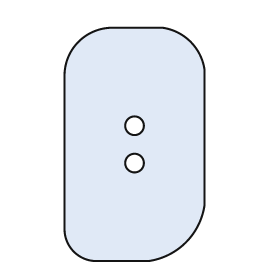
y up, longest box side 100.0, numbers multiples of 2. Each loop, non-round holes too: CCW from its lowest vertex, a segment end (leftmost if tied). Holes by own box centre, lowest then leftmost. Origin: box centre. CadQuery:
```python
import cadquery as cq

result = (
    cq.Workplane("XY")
    .moveTo(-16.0, -50.0)
    .lineTo(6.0, -50.0)
    .threePointArc((22.0, -42.0), (30.0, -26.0))
    .lineTo(30.0, 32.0)
    .threePointArc((24.0, 44.0), (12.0, 50.0))
    .lineTo(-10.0, 50.0)
    .threePointArc((-24.0, 44.0), (-30.0, 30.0))
    .lineTo(-30.0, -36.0)
    .threePointArc((-26.0, -46.0), (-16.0, -50.0))
    .close()
    .moveTo(0.0, -8.0)
    .circle(4.0)
    .moveTo(0.0, 8.0)
    .circle(4.0)
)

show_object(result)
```